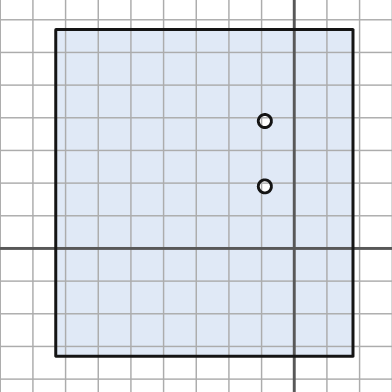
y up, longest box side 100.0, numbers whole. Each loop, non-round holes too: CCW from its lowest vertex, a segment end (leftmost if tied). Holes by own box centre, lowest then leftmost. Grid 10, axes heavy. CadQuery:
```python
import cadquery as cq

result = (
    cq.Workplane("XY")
    .moveTo(-73.0, -33.0)
    .lineTo(18.0, -33.0)
    .lineTo(18.0, 67.0)
    .lineTo(-73.0, 67.0)
    .close()
    .moveTo(-9.0, 19.0)
    .circle(2.0)
    .moveTo(-9.0, 39.0)
    .circle(2.0)
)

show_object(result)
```